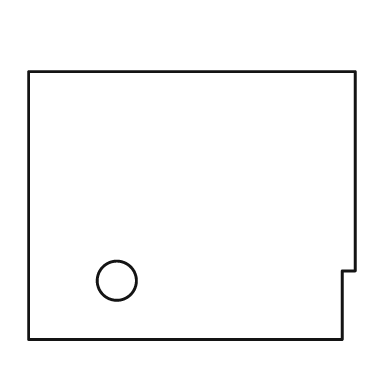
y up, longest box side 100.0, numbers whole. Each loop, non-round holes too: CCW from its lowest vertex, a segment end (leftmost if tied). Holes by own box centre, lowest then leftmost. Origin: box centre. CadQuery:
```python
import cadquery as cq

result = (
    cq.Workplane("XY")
    .moveTo(-50.0, -41.0)
    .lineTo(46.0, -41.0)
    .lineTo(46.0, -20.0)
    .lineTo(50.0, -20.0)
    .lineTo(50.0, 41.0)
    .lineTo(-50.0, 41.0)
    .close()
    .moveTo(-23.0, -23.0)
    .circle(6.0)
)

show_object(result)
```